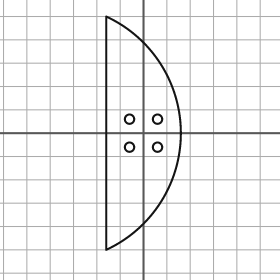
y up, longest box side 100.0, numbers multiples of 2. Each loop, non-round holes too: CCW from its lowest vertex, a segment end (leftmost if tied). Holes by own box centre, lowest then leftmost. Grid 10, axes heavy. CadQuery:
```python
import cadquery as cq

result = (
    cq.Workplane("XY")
    .moveTo(-16.0, -50.0)
    .threePointArc((16.0, 0.0), (-16.0, 50.0))
    .close()
    .moveTo(-6.0, -6.0)
    .circle(2.0)
    .moveTo(6.0, -6.0)
    .circle(2.0)
    .moveTo(-6.0, 6.0)
    .circle(2.0)
    .moveTo(6.0, 6.0)
    .circle(2.0)
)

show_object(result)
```